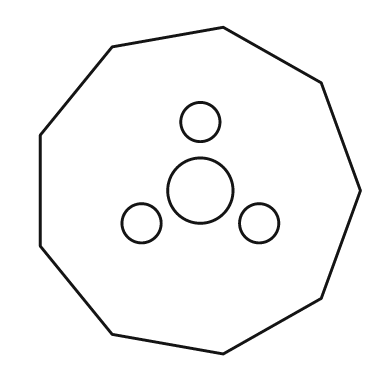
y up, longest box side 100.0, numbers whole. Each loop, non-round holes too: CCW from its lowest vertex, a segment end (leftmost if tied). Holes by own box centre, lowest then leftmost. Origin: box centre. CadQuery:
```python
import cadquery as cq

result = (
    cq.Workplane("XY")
    .moveTo(7.0, -50.0)
    .lineTo(37.0, -33.0)
    .lineTo(49.0, 0.0)
    .lineTo(37.0, 33.0)
    .lineTo(7.0, 50.0)
    .lineTo(-27.0, 44.0)
    .lineTo(-49.0, 17.0)
    .lineTo(-49.0, -17.0)
    .lineTo(-27.0, -44.0)
    .close()
    .moveTo(-18.0, -10.0)
    .circle(6.0)
    .moveTo(18.0, -10.0)
    .circle(6.0)
    .moveTo(0.0, 0.0)
    .circle(10.0)
    .moveTo(0.0, 21.0)
    .circle(6.0)
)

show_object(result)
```